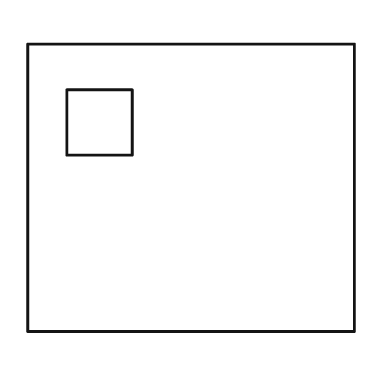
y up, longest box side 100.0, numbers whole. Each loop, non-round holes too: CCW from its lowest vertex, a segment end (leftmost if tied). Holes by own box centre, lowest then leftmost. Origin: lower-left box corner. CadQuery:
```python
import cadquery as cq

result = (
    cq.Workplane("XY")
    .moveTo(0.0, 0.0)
    .lineTo(100.0, 0.0)
    .lineTo(100.0, 88.0)
    .lineTo(0.0, 88.0)
    .close()
    .moveTo(12.0, 54.0)
    .lineTo(32.0, 54.0)
    .lineTo(32.0, 74.0)
    .lineTo(12.0, 74.0)
    .close()
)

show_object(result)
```